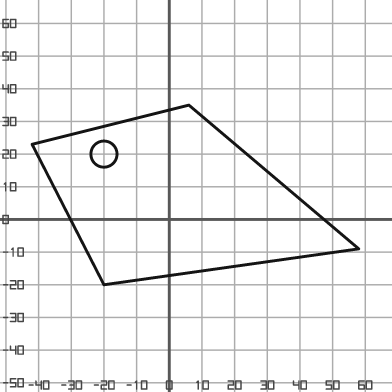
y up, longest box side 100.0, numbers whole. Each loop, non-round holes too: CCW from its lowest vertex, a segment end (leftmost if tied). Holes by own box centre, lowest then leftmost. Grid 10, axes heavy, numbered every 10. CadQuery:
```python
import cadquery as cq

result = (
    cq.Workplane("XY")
    .moveTo(-20.0, -20.0)
    .lineTo(58.0, -9.0)
    .lineTo(6.0, 35.0)
    .lineTo(-42.0, 23.0)
    .close()
    .moveTo(-20.0, 20.0)
    .circle(4.0)
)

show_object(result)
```